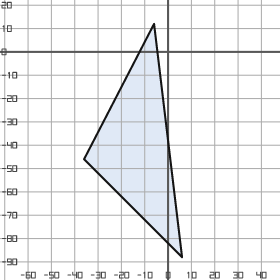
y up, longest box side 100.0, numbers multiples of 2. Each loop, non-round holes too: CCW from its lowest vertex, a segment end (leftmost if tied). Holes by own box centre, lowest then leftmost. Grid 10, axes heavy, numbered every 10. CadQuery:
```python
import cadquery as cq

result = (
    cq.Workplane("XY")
    .moveTo(6.0, -88.0)
    .lineTo(-6.0, 12.0)
    .lineTo(-36.0, -46.0)
    .close()
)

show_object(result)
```